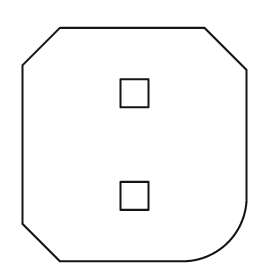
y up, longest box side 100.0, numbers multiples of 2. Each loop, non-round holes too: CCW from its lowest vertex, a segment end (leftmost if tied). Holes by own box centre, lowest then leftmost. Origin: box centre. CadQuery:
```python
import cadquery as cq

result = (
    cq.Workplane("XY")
    .moveTo(-32.0, -50.0)
    .lineTo(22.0, -50.0)
    .threePointArc((40.0, -42.0), (48.0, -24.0))
    .lineTo(48.0, 32.0)
    .lineTo(30.0, 50.0)
    .lineTo(-32.0, 50.0)
    .lineTo(-48.0, 34.0)
    .lineTo(-48.0, -34.0)
    .close()
    .moveTo(-6.0, -28.0)
    .lineTo(6.0, -28.0)
    .lineTo(6.0, -16.0)
    .lineTo(-6.0, -16.0)
    .close()
    .moveTo(-6.0, 16.0)
    .lineTo(6.0, 16.0)
    .lineTo(6.0, 28.0)
    .lineTo(-6.0, 28.0)
    .close()
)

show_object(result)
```